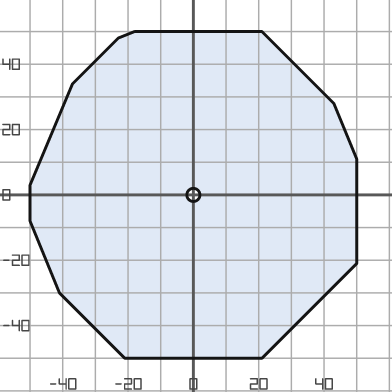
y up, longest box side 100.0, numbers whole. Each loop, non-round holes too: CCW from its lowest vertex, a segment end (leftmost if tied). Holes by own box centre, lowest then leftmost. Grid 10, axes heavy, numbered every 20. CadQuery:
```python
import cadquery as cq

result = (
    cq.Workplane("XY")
    .moveTo(-21.0, -50.0)
    .lineTo(21.0, -50.0)
    .lineTo(50.0, -21.0)
    .lineTo(50.0, 11.0)
    .lineTo(43.0, 28.0)
    .lineTo(21.0, 50.0)
    .lineTo(-18.0, 50.0)
    .lineTo(-23.0, 48.0)
    .lineTo(-37.0, 34.0)
    .lineTo(-50.0, 3.0)
    .lineTo(-50.0, -8.0)
    .lineTo(-41.0, -30.0)
    .close()
    .moveTo(0.0, 0.0)
    .circle(2.0)
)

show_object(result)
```